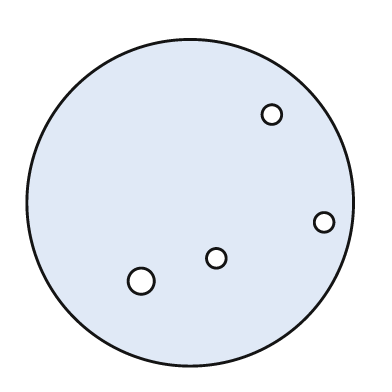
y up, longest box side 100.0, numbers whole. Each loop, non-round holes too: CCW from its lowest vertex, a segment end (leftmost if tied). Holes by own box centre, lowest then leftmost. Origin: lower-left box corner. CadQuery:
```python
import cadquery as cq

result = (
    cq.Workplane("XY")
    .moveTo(50.0, 50.0)
    .circle(50.0)
    .moveTo(35.0, 26.0)
    .circle(4.0)
    .moveTo(58.0, 33.0)
    .circle(3.0)
    .moveTo(91.0, 44.0)
    .circle(3.0)
    .moveTo(75.0, 77.0)
    .circle(3.0)
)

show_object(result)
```